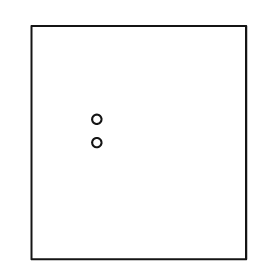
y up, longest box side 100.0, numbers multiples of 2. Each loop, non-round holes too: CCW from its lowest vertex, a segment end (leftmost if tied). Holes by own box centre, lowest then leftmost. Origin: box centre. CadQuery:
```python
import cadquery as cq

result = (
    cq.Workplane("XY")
    .moveTo(-46.0, -50.0)
    .lineTo(46.0, -50.0)
    .lineTo(46.0, 50.0)
    .lineTo(-46.0, 50.0)
    .close()
    .moveTo(-18.0, 0.0)
    .circle(2.0)
    .moveTo(-18.0, 10.0)
    .circle(2.0)
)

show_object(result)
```